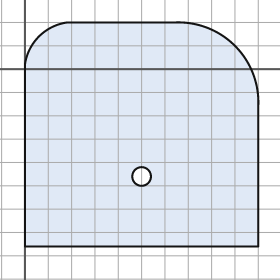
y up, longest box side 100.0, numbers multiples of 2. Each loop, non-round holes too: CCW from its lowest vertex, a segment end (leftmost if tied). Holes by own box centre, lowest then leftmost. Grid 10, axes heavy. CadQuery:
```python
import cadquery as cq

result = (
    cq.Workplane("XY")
    .moveTo(0.0, -76.0)
    .lineTo(100.0, -76.0)
    .lineTo(100.0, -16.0)
    .threePointArc((90.0, 10.0), (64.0, 20.0))
    .lineTo(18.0, 20.0)
    .threePointArc((6.0, 14.0), (0.0, 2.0))
    .close()
    .moveTo(50.0, -46.0)
    .circle(4.0)
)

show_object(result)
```